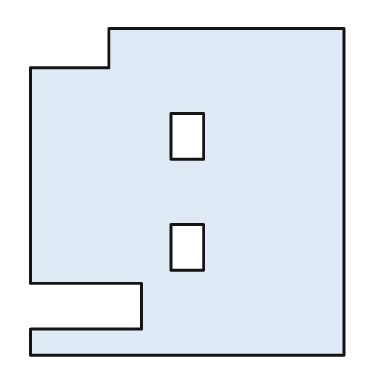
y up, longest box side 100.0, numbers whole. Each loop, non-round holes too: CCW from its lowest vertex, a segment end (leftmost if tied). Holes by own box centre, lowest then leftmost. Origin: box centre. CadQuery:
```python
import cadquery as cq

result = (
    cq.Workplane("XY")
    .moveTo(-48.0, -50.0)
    .lineTo(48.0, -50.0)
    .lineTo(48.0, 50.0)
    .lineTo(-24.0, 50.0)
    .lineTo(-24.0, 38.0)
    .lineTo(-48.0, 38.0)
    .lineTo(-48.0, -28.0)
    .lineTo(-14.0, -28.0)
    .lineTo(-14.0, -42.0)
    .lineTo(-48.0, -42.0)
    .close()
    .moveTo(-5.0, -24.0)
    .lineTo(5.0, -24.0)
    .lineTo(5.0, -10.0)
    .lineTo(-5.0, -10.0)
    .close()
    .moveTo(-5.0, 10.0)
    .lineTo(5.0, 10.0)
    .lineTo(5.0, 24.0)
    .lineTo(-5.0, 24.0)
    .close()
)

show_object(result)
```